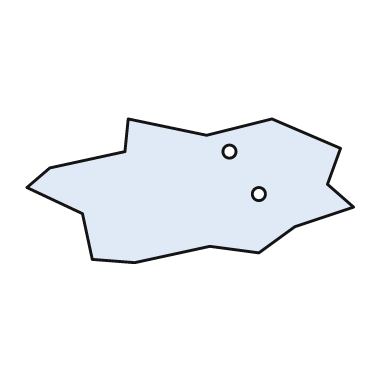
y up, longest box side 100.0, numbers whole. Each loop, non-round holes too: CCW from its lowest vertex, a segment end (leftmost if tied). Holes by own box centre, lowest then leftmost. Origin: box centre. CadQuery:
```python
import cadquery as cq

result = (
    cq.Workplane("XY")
    .moveTo(-17.0, -22.0)
    .lineTo(6.0, -17.0)
    .lineTo(21.0, -19.0)
    .lineTo(32.0, -11.0)
    .lineTo(50.0, -5.0)
    .lineTo(42.0, 2.0)
    .lineTo(46.0, 13.0)
    .lineTo(25.0, 22.0)
    .lineTo(5.0, 17.0)
    .lineTo(-19.0, 22.0)
    .lineTo(-20.0, 12.0)
    .lineTo(-43.0, 7.0)
    .lineTo(-50.0, 1.0)
    .lineTo(-33.0, -7.0)
    .lineTo(-30.0, -21.0)
    .close()
    .moveTo(21.0, -1.0)
    .circle(2.0)
    .moveTo(12.0, 12.0)
    .circle(2.0)
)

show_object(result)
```